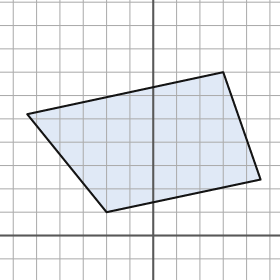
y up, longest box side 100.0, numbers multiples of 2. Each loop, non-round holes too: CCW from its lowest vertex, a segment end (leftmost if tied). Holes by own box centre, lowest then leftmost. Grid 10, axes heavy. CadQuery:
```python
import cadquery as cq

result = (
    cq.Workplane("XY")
    .moveTo(-20.0, 10.0)
    .lineTo(46.0, 24.0)
    .lineTo(30.0, 70.0)
    .lineTo(-54.0, 52.0)
    .close()
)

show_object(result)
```